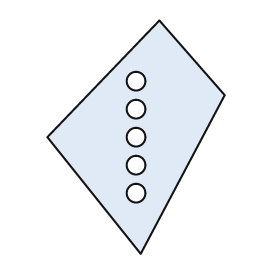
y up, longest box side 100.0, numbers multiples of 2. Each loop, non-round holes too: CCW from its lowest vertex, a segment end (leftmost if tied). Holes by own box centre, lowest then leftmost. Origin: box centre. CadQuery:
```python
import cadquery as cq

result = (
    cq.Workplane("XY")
    .moveTo(2.0, -50.0)
    .lineTo(38.0, 18.0)
    .lineTo(10.0, 50.0)
    .lineTo(-38.0, 0.0)
    .close()
    .moveTo(0.0, -24.0)
    .circle(4.0)
    .moveTo(0.0, -12.0)
    .circle(4.0)
    .moveTo(0.0, 0.0)
    .circle(4.0)
    .moveTo(0.0, 12.0)
    .circle(4.0)
    .moveTo(0.0, 24.0)
    .circle(4.0)
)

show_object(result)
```